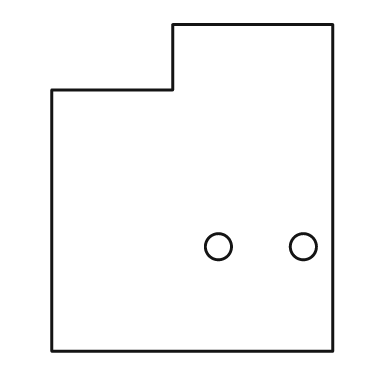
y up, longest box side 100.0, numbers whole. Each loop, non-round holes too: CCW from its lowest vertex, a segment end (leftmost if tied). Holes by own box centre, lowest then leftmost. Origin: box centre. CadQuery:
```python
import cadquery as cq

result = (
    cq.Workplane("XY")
    .moveTo(-43.0, -50.0)
    .lineTo(43.0, -50.0)
    .lineTo(43.0, 50.0)
    .lineTo(-6.0, 50.0)
    .lineTo(-6.0, 30.0)
    .lineTo(-43.0, 30.0)
    .close()
    .moveTo(8.0, -18.0)
    .circle(4.0)
    .moveTo(34.0, -18.0)
    .circle(4.0)
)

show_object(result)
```